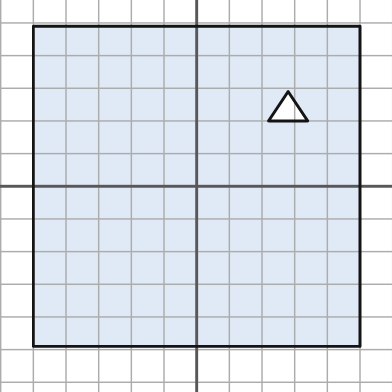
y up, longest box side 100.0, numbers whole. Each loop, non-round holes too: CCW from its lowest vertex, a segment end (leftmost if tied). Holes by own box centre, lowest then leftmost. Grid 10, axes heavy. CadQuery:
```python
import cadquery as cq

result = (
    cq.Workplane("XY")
    .moveTo(-50.0, -49.0)
    .lineTo(50.0, -49.0)
    .lineTo(50.0, 49.0)
    .lineTo(-50.0, 49.0)
    .close()
    .moveTo(22.0, 20.0)
    .lineTo(34.0, 20.0)
    .lineTo(28.0, 29.0)
    .close()
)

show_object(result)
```